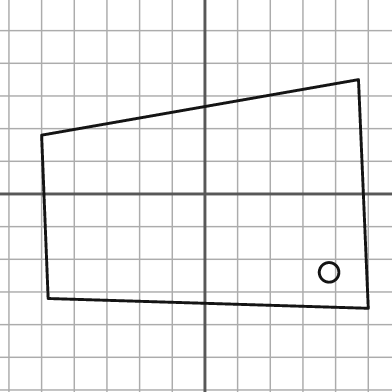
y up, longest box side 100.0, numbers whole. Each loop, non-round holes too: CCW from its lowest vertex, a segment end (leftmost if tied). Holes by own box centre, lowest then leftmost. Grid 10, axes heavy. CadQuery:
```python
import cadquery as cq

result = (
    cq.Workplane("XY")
    .moveTo(50.0, -35.0)
    .lineTo(47.0, 35.0)
    .lineTo(-50.0, 18.0)
    .lineTo(-48.0, -32.0)
    .close()
    .moveTo(38.0, -24.0)
    .circle(3.0)
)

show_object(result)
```